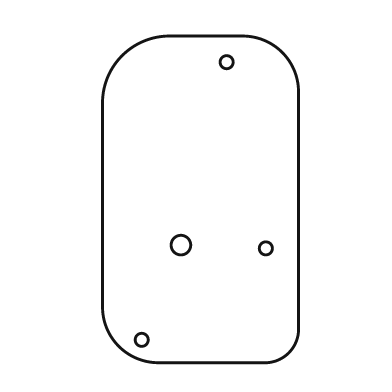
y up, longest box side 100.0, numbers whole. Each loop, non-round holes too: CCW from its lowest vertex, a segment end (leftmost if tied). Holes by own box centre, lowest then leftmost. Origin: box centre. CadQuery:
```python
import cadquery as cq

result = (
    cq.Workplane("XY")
    .moveTo(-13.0, -50.0)
    .lineTo(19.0, -50.0)
    .threePointArc((27.0, -47.0), (30.0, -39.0))
    .lineTo(30.0, 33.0)
    .threePointArc((25.0, 45.0), (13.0, 50.0))
    .lineTo(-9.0, 50.0)
    .threePointArc((-24.0, 44.0), (-30.0, 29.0))
    .lineTo(-30.0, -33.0)
    .threePointArc((-25.0, -45.0), (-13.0, -50.0))
    .close()
    .moveTo(-18.0, -43.0)
    .circle(2.0)
    .moveTo(20.0, -15.0)
    .circle(2.0)
    .moveTo(-6.0, -14.0)
    .circle(3.0)
    .moveTo(8.0, 42.0)
    .circle(2.0)
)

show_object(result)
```